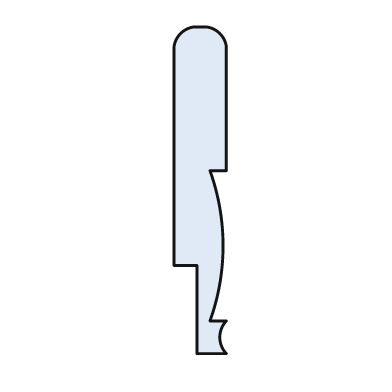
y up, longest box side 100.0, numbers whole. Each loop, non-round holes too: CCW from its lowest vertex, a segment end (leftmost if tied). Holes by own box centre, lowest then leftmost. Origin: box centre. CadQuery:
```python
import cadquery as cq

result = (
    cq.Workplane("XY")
    .moveTo(-1.0, -50.0)
    .lineTo(8.0, -50.0)
    .threePointArc((6.0, -45.0), (8.0, -40.0))
    .lineTo(3.0, -40.0)
    .threePointArc((7.0, -17.0), (3.0, 6.0))
    .lineTo(8.0, 6.0)
    .lineTo(8.0, 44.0)
    .threePointArc((6.0, 48.0), (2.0, 50.0))
    .lineTo(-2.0, 50.0)
    .threePointArc((-6.0, 48.0), (-8.0, 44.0))
    .lineTo(-8.0, -23.0)
    .lineTo(-1.0, -23.0)
    .close()
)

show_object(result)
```